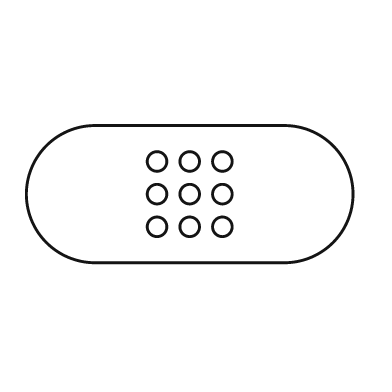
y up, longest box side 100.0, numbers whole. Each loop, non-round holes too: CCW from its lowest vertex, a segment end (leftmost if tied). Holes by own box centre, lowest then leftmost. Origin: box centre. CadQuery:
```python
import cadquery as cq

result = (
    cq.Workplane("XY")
    .moveTo(-29.0, -21.0)
    .lineTo(29.0, -21.0)
    .threePointArc((50.0, 0.0), (29.0, 21.0))
    .lineTo(-29.0, 21.0)
    .threePointArc((-50.0, 0.0), (-29.0, -21.0))
    .close()
    .moveTo(-10.0, -10.0)
    .circle(3.0)
    .moveTo(0.0, -10.0)
    .circle(3.0)
    .moveTo(10.0, -10.0)
    .circle(3.0)
    .moveTo(-10.0, 0.0)
    .circle(3.0)
    .moveTo(0.0, 0.0)
    .circle(3.0)
    .moveTo(10.0, 0.0)
    .circle(3.0)
    .moveTo(-10.0, 10.0)
    .circle(3.0)
    .moveTo(0.0, 10.0)
    .circle(3.0)
    .moveTo(10.0, 10.0)
    .circle(3.0)
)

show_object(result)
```